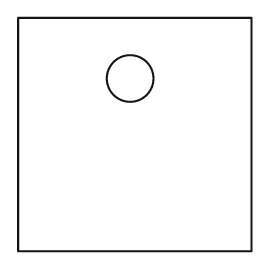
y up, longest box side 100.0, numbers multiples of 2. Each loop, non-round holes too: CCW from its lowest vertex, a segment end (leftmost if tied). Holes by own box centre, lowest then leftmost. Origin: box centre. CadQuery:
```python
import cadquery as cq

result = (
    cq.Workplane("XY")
    .moveTo(-50.0, -50.0)
    .lineTo(50.0, -50.0)
    .lineTo(50.0, 50.0)
    .lineTo(-50.0, 50.0)
    .close()
    .moveTo(-2.0, 24.0)
    .circle(10.0)
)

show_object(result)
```